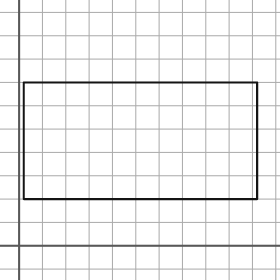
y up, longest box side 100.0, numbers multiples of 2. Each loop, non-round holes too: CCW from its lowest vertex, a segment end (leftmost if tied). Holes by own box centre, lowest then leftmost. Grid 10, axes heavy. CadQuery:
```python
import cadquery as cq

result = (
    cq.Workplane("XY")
    .moveTo(2.0, 20.0)
    .lineTo(102.0, 20.0)
    .lineTo(102.0, 70.0)
    .lineTo(2.0, 70.0)
    .close()
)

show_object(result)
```